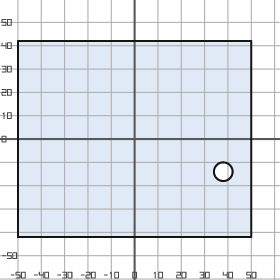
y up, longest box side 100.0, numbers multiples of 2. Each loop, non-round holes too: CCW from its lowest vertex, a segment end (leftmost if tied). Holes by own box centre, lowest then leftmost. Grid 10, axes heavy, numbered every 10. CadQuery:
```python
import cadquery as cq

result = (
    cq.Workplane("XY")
    .moveTo(-50.0, -42.0)
    .lineTo(50.0, -42.0)
    .lineTo(50.0, 42.0)
    .lineTo(-50.0, 42.0)
    .close()
    .moveTo(38.0, -14.0)
    .circle(4.0)
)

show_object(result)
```